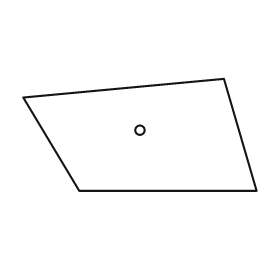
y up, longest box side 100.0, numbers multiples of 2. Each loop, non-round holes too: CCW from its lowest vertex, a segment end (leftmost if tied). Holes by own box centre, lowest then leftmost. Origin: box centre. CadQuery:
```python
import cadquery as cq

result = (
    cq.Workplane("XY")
    .moveTo(-26.0, -24.0)
    .lineTo(50.0, -24.0)
    .lineTo(36.0, 24.0)
    .lineTo(-50.0, 16.0)
    .close()
    .moveTo(0.0, 2.0)
    .circle(2.0)
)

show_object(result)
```